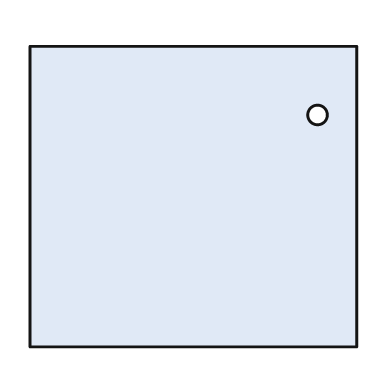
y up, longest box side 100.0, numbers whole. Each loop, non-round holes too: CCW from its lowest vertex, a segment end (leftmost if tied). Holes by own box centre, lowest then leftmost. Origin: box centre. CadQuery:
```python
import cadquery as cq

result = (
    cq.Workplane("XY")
    .moveTo(-50.0, -46.0)
    .lineTo(50.0, -46.0)
    .lineTo(50.0, 46.0)
    .lineTo(-50.0, 46.0)
    .close()
    .moveTo(38.0, 25.0)
    .circle(3.0)
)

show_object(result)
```